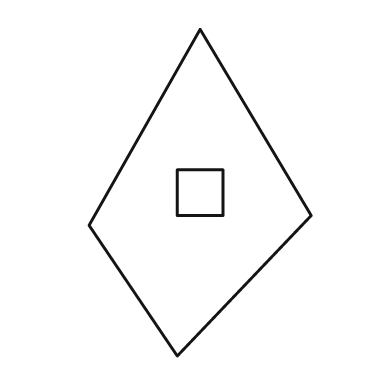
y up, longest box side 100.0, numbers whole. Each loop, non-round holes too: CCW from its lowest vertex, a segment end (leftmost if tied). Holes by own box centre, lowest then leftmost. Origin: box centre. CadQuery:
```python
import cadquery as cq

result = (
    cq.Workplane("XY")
    .moveTo(-7.0, -50.0)
    .lineTo(34.0, -7.0)
    .lineTo(0.0, 50.0)
    .lineTo(-34.0, -10.0)
    .close()
    .moveTo(-7.0, -7.0)
    .lineTo(7.0, -7.0)
    .lineTo(7.0, 7.0)
    .lineTo(-7.0, 7.0)
    .close()
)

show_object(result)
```